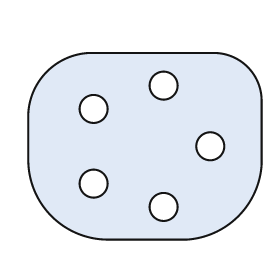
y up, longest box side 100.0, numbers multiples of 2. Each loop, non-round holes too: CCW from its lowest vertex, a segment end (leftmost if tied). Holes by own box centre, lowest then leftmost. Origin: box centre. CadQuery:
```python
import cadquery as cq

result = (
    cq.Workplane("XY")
    .moveTo(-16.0, -40.0)
    .lineTo(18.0, -40.0)
    .threePointArc((40.0, -30.0), (50.0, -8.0))
    .lineTo(50.0, 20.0)
    .threePointArc((44.0, 34.0), (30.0, 40.0))
    .lineTo(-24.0, 40.0)
    .threePointArc((-42.0, 32.0), (-50.0, 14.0))
    .lineTo(-50.0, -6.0)
    .threePointArc((-40.0, -30.0), (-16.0, -40.0))
    .close()
    .moveTo(8.0, -26.0)
    .circle(6.0)
    .moveTo(-22.0, -16.0)
    .circle(6.0)
    .moveTo(28.0, 0.0)
    .circle(6.0)
    .moveTo(-22.0, 16.0)
    .circle(6.0)
    .moveTo(8.0, 26.0)
    .circle(6.0)
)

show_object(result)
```